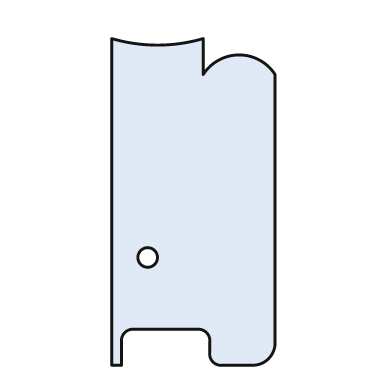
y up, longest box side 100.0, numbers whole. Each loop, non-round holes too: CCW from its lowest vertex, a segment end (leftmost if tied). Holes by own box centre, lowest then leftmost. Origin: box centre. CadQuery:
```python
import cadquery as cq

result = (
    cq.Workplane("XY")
    .moveTo(-25.0, -50.0)
    .lineTo(-22.0, -50.0)
    .lineTo(-22.0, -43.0)
    .threePointArc((-21.0, -40.0), (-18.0, -39.0))
    .lineTo(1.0, -39.0)
    .threePointArc((4.0, -40.0), (5.0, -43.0))
    .lineTo(5.0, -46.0)
    .threePointArc((6.0, -49.0), (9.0, -50.0))
    .lineTo(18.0, -50.0)
    .threePointArc((23.0, -48.0), (25.0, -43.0))
    .lineTo(25.0, 39.0)
    .threePointArc((14.0, 45.0), (3.0, 39.0))
    .lineTo(3.0, 50.0)
    .threePointArc((-11.0, 48.0), (-25.0, 50.0))
    .close()
    .moveTo(-14.0, -17.0)
    .circle(3.0)
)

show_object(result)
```